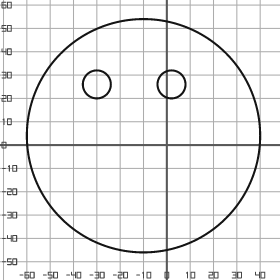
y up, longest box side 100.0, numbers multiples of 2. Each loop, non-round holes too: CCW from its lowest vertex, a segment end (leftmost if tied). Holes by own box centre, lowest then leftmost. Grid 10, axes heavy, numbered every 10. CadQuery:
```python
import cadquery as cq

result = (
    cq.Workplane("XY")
    .moveTo(-10.0, 4.0)
    .circle(50.0)
    .moveTo(-30.0, 26.0)
    .circle(6.0)
    .moveTo(2.0, 26.0)
    .circle(6.0)
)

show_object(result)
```